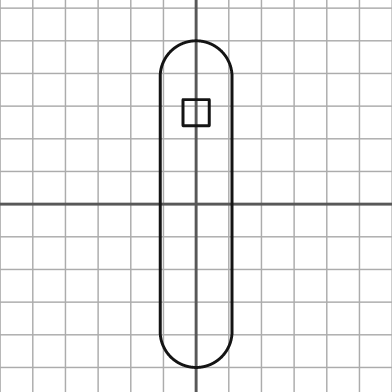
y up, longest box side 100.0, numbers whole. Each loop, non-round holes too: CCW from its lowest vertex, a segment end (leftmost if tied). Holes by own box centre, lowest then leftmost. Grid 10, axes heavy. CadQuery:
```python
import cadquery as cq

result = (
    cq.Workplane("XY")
    .moveTo(-11.0, -39.0)
    .threePointArc((0.0, -50.0), (11.0, -39.0))
    .lineTo(11.0, 39.0)
    .threePointArc((0.0, 50.0), (-11.0, 39.0))
    .close()
    .moveTo(-4.0, 24.0)
    .lineTo(4.0, 24.0)
    .lineTo(4.0, 32.0)
    .lineTo(-4.0, 32.0)
    .close()
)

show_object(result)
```